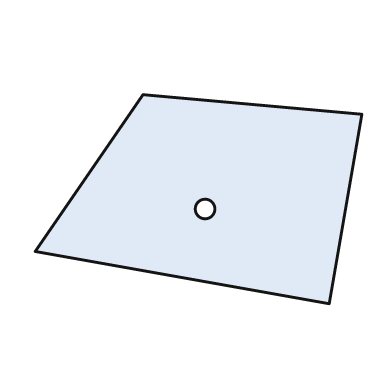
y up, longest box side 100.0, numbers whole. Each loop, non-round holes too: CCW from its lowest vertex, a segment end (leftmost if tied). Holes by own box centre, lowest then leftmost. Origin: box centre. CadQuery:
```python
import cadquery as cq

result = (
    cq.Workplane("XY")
    .moveTo(40.0, -32.0)
    .lineTo(50.0, 26.0)
    .lineTo(-17.0, 32.0)
    .lineTo(-50.0, -16.0)
    .close()
    .moveTo(2.0, -3.0)
    .circle(3.0)
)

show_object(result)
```